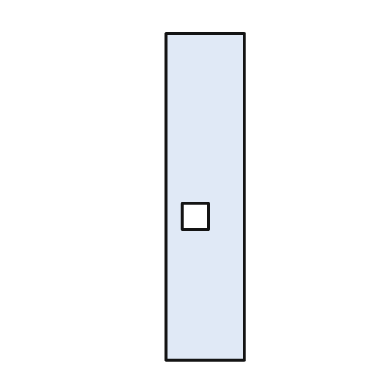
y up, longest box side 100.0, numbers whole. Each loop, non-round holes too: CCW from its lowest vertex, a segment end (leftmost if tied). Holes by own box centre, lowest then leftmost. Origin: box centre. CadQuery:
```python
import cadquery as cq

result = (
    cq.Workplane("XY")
    .moveTo(-12.0, -50.0)
    .lineTo(12.0, -50.0)
    .lineTo(12.0, 50.0)
    .lineTo(-12.0, 50.0)
    .close()
    .moveTo(-7.0, -10.0)
    .lineTo(1.0, -10.0)
    .lineTo(1.0, -2.0)
    .lineTo(-7.0, -2.0)
    .close()
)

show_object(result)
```